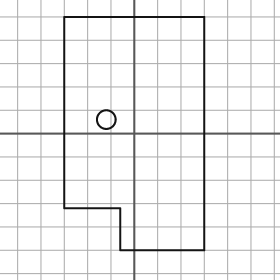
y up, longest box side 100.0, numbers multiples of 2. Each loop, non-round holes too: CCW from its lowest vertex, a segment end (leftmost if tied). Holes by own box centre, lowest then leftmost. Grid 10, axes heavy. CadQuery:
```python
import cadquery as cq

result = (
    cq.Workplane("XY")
    .moveTo(-6.0, -50.0)
    .lineTo(30.0, -50.0)
    .lineTo(30.0, 50.0)
    .lineTo(-30.0, 50.0)
    .lineTo(-30.0, -32.0)
    .lineTo(-6.0, -32.0)
    .close()
    .moveTo(-12.0, 6.0)
    .circle(4.0)
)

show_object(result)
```